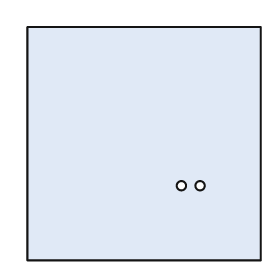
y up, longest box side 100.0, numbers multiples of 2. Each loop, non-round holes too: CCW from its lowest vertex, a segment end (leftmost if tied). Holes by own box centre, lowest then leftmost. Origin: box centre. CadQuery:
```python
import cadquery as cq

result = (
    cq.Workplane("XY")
    .moveTo(-50.0, -50.0)
    .lineTo(50.0, -50.0)
    .lineTo(50.0, 50.0)
    .lineTo(-50.0, 50.0)
    .close()
    .moveTo(16.0, -18.0)
    .circle(2.0)
    .moveTo(24.0, -18.0)
    .circle(2.0)
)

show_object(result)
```